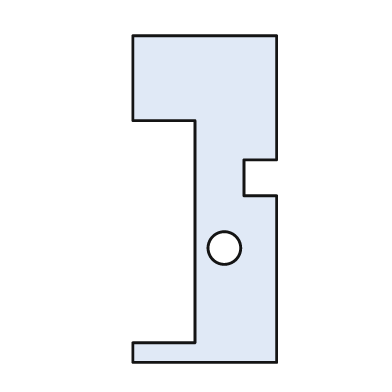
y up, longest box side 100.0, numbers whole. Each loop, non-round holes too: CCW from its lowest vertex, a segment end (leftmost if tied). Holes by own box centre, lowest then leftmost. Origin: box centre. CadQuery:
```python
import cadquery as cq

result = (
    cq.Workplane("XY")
    .moveTo(-22.0, -50.0)
    .lineTo(22.0, -50.0)
    .lineTo(22.0, 1.0)
    .lineTo(12.0, 1.0)
    .lineTo(12.0, 12.0)
    .lineTo(22.0, 12.0)
    .lineTo(22.0, 50.0)
    .lineTo(-22.0, 50.0)
    .lineTo(-22.0, 24.0)
    .lineTo(-3.0, 24.0)
    .lineTo(-3.0, -44.0)
    .lineTo(-22.0, -44.0)
    .close()
    .moveTo(6.0, -15.0)
    .circle(5.0)
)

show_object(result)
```